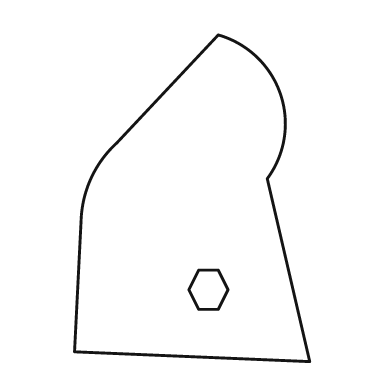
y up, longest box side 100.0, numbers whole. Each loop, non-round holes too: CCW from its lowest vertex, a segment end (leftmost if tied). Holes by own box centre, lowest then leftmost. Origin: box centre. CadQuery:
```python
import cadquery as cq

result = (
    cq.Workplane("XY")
    .moveTo(36.0, -50.0)
    .lineTo(23.0, 6.0)
    .threePointArc((27.0, 32.0), (8.0, 50.0))
    .lineTo(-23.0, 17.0)
    .threePointArc((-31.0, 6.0), (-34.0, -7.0))
    .lineTo(-36.0, -47.0)
    .close()
    .moveTo(2.0, -34.0)
    .lineTo(8.0, -34.0)
    .lineTo(11.0, -28.0)
    .lineTo(8.0, -22.0)
    .lineTo(2.0, -22.0)
    .lineTo(-1.0, -28.0)
    .close()
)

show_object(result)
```